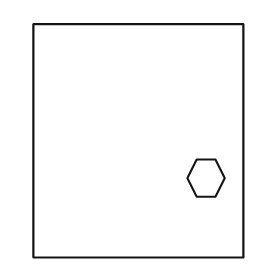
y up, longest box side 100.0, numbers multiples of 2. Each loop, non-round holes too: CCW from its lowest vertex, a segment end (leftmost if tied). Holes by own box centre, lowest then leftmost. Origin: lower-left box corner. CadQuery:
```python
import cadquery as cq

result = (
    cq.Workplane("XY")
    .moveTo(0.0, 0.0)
    .lineTo(90.0, 0.0)
    .lineTo(90.0, 100.0)
    .lineTo(0.0, 100.0)
    .close()
    .moveTo(70.0, 26.0)
    .lineTo(78.0, 26.0)
    .lineTo(82.0, 34.0)
    .lineTo(78.0, 42.0)
    .lineTo(70.0, 42.0)
    .lineTo(66.0, 34.0)
    .close()
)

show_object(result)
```